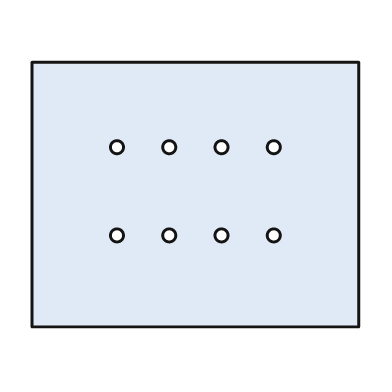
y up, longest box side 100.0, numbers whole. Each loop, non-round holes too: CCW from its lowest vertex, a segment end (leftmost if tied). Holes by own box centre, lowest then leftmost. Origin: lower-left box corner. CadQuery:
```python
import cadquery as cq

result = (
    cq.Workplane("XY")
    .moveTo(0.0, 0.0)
    .lineTo(100.0, 0.0)
    .lineTo(100.0, 81.0)
    .lineTo(0.0, 81.0)
    .close()
    .moveTo(26.0, 28.0)
    .circle(2.0)
    .moveTo(42.0, 28.0)
    .circle(2.0)
    .moveTo(58.0, 28.0)
    .circle(2.0)
    .moveTo(74.0, 28.0)
    .circle(2.0)
    .moveTo(26.0, 55.0)
    .circle(2.0)
    .moveTo(42.0, 55.0)
    .circle(2.0)
    .moveTo(58.0, 55.0)
    .circle(2.0)
    .moveTo(74.0, 55.0)
    .circle(2.0)
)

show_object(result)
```